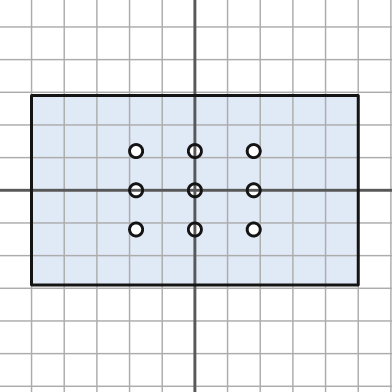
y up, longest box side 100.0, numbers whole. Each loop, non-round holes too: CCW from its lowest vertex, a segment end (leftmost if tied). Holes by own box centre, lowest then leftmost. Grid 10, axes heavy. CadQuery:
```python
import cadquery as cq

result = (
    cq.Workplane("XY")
    .moveTo(-50.0, -29.0)
    .lineTo(50.0, -29.0)
    .lineTo(50.0, 29.0)
    .lineTo(-50.0, 29.0)
    .close()
    .moveTo(-18.0, -12.0)
    .circle(2.0)
    .moveTo(0.0, -12.0)
    .circle(2.0)
    .moveTo(18.0, -12.0)
    .circle(2.0)
    .moveTo(-18.0, 0.0)
    .circle(2.0)
    .moveTo(0.0, 0.0)
    .circle(2.0)
    .moveTo(18.0, 0.0)
    .circle(2.0)
    .moveTo(-18.0, 12.0)
    .circle(2.0)
    .moveTo(0.0, 12.0)
    .circle(2.0)
    .moveTo(18.0, 12.0)
    .circle(2.0)
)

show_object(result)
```